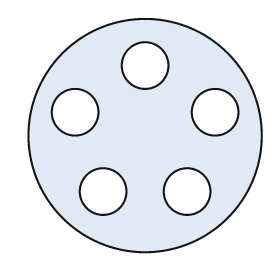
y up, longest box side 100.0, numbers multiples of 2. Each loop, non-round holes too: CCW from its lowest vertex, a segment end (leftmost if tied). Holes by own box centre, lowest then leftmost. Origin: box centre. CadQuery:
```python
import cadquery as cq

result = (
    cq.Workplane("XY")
    .moveTo(0.0, 0.0)
    .circle(50.0)
    .moveTo(-18.0, -24.0)
    .circle(10.0)
    .moveTo(18.0, -24.0)
    .circle(10.0)
    .moveTo(-30.0, 10.0)
    .circle(10.0)
    .moveTo(30.0, 10.0)
    .circle(10.0)
    .moveTo(0.0, 30.0)
    .circle(10.0)
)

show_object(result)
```